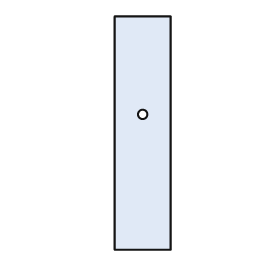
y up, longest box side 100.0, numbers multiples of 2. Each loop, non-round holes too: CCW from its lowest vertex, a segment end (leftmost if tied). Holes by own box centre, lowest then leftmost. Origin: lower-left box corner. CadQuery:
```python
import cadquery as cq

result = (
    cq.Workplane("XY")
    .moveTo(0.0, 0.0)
    .lineTo(24.0, 0.0)
    .lineTo(24.0, 100.0)
    .lineTo(0.0, 100.0)
    .close()
    .moveTo(12.0, 58.0)
    .circle(2.0)
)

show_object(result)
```